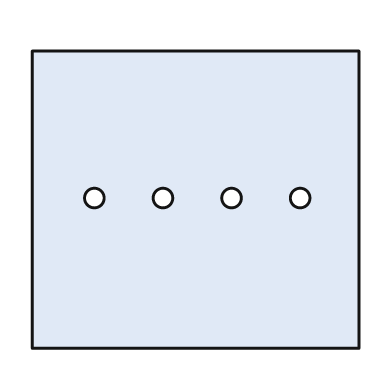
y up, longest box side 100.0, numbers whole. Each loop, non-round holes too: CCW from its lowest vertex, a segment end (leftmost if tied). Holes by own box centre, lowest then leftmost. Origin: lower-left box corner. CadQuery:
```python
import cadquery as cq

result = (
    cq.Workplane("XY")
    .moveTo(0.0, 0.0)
    .lineTo(100.0, 0.0)
    .lineTo(100.0, 91.0)
    .lineTo(0.0, 91.0)
    .close()
    .moveTo(19.0, 46.0)
    .circle(3.0)
    .moveTo(40.0, 46.0)
    .circle(3.0)
    .moveTo(61.0, 46.0)
    .circle(3.0)
    .moveTo(82.0, 46.0)
    .circle(3.0)
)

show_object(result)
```